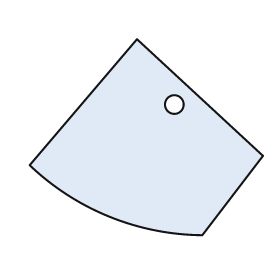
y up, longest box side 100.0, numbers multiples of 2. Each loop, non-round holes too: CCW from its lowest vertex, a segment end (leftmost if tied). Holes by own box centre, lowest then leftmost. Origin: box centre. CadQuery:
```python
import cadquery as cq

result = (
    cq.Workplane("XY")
    .moveTo(24.0, -42.0)
    .lineTo(50.0, -8.0)
    .lineTo(-4.0, 42.0)
    .lineTo(-50.0, -12.0)
    .threePointArc((-16.0, -34.0), (24.0, -42.0))
    .close()
    .moveTo(12.0, 14.0)
    .circle(4.0)
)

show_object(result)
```